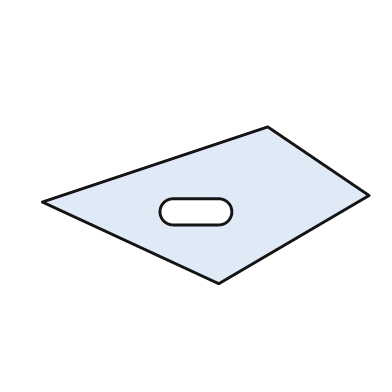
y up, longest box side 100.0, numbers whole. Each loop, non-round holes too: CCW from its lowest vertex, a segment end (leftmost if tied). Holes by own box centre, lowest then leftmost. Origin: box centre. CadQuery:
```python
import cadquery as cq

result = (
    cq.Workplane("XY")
    .moveTo(4.0, -24.0)
    .lineTo(50.0, 3.0)
    .lineTo(19.0, 24.0)
    .lineTo(-50.0, 1.0)
    .close()
    .moveTo(-10.0, -6.0)
    .lineTo(4.0, -6.0)
    .threePointArc((8.0, -2.0), (4.0, 2.0))
    .lineTo(-10.0, 2.0)
    .threePointArc((-14.0, -2.0), (-10.0, -6.0))
    .close()
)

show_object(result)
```